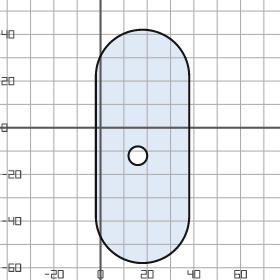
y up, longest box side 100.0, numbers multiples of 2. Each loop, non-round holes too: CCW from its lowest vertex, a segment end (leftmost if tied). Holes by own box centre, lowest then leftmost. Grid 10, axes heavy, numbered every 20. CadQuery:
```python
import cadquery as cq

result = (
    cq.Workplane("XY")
    .moveTo(-2.0, -38.0)
    .threePointArc((18.0, -58.0), (38.0, -38.0))
    .lineTo(38.0, 22.0)
    .threePointArc((18.0, 42.0), (-2.0, 22.0))
    .close()
    .moveTo(16.0, -12.0)
    .circle(4.0)
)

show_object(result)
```